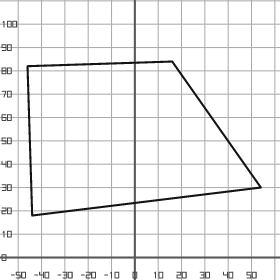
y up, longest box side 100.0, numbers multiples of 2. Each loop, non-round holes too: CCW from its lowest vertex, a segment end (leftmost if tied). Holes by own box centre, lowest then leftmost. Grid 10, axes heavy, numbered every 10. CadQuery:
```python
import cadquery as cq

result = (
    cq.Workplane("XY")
    .moveTo(-44.0, 18.0)
    .lineTo(54.0, 30.0)
    .lineTo(16.0, 84.0)
    .lineTo(-46.0, 82.0)
    .close()
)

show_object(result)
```